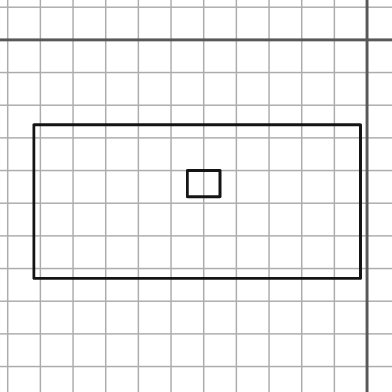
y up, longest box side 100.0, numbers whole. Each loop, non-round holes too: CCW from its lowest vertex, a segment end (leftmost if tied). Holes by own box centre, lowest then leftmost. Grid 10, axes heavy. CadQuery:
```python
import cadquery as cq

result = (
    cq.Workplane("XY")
    .moveTo(-102.0, -73.0)
    .lineTo(-2.0, -73.0)
    .lineTo(-2.0, -26.0)
    .lineTo(-102.0, -26.0)
    .close()
    .moveTo(-55.0, -48.0)
    .lineTo(-45.0, -48.0)
    .lineTo(-45.0, -40.0)
    .lineTo(-55.0, -40.0)
    .close()
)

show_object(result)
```